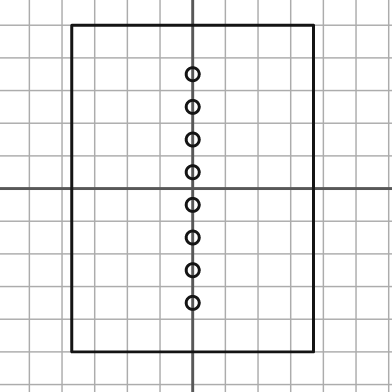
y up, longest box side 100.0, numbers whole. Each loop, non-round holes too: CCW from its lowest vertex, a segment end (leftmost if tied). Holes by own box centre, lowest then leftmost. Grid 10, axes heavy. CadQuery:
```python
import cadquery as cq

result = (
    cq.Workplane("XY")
    .moveTo(-37.0, -50.0)
    .lineTo(37.0, -50.0)
    .lineTo(37.0, 50.0)
    .lineTo(-37.0, 50.0)
    .close()
    .moveTo(0.0, -35.0)
    .circle(2.0)
    .moveTo(0.0, -25.0)
    .circle(2.0)
    .moveTo(0.0, -15.0)
    .circle(2.0)
    .moveTo(0.0, -5.0)
    .circle(2.0)
    .moveTo(0.0, 5.0)
    .circle(2.0)
    .moveTo(0.0, 15.0)
    .circle(2.0)
    .moveTo(0.0, 25.0)
    .circle(2.0)
    .moveTo(0.0, 35.0)
    .circle(2.0)
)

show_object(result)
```